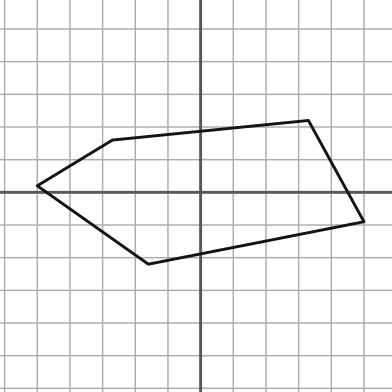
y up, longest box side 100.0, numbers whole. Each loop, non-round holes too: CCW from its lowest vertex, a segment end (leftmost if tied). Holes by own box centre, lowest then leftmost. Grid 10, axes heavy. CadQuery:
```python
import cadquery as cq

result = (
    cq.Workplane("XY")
    .moveTo(-16.0, -22.0)
    .lineTo(50.0, -9.0)
    .lineTo(33.0, 22.0)
    .lineTo(-27.0, 16.0)
    .lineTo(-50.0, 2.0)
    .close()
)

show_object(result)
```